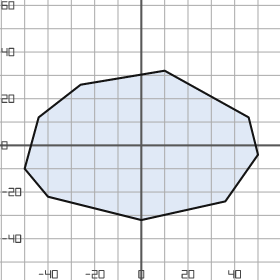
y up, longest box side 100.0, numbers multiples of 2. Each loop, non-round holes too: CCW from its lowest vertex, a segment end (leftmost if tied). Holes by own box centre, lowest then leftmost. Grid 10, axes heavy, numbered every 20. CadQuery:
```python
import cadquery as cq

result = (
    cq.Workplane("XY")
    .moveTo(0.0, -32.0)
    .lineTo(36.0, -24.0)
    .lineTo(50.0, -4.0)
    .lineTo(46.0, 12.0)
    .lineTo(10.0, 32.0)
    .lineTo(-26.0, 26.0)
    .lineTo(-44.0, 12.0)
    .lineTo(-50.0, -10.0)
    .lineTo(-40.0, -22.0)
    .close()
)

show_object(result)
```